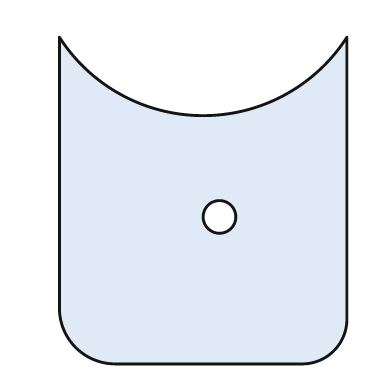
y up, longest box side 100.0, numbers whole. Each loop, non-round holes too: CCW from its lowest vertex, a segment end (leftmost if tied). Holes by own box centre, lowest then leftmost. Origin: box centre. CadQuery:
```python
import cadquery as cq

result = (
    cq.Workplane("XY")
    .moveTo(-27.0, -50.0)
    .lineTo(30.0, -50.0)
    .threePointArc((40.0, -46.0), (44.0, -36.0))
    .lineTo(44.0, 50.0)
    .threePointArc((0.0, 26.0), (-44.0, 50.0))
    .lineTo(-44.0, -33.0)
    .threePointArc((-39.0, -45.0), (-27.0, -50.0))
    .close()
    .moveTo(5.0, -5.0)
    .circle(5.0)
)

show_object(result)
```